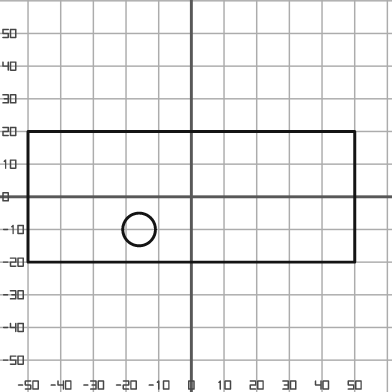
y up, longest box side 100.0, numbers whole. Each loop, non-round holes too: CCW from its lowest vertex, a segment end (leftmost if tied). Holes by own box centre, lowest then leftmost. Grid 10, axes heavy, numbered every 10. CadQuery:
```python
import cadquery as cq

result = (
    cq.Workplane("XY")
    .moveTo(-50.0, -20.0)
    .lineTo(50.0, -20.0)
    .lineTo(50.0, 20.0)
    .lineTo(-50.0, 20.0)
    .close()
    .moveTo(-16.0, -10.0)
    .circle(5.0)
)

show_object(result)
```